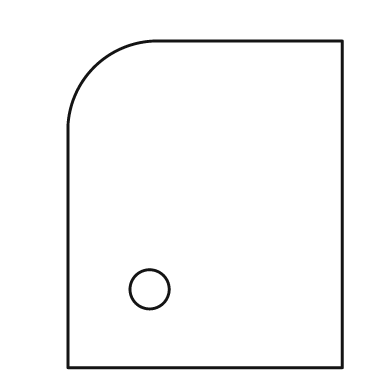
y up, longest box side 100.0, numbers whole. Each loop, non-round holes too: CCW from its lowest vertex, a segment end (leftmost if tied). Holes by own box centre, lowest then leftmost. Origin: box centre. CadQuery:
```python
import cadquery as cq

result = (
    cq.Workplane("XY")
    .moveTo(-42.0, -50.0)
    .lineTo(42.0, -50.0)
    .lineTo(42.0, 50.0)
    .lineTo(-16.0, 50.0)
    .threePointArc((-34.0, 42.0), (-42.0, 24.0))
    .close()
    .moveTo(-17.0, -26.0)
    .circle(6.0)
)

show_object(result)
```